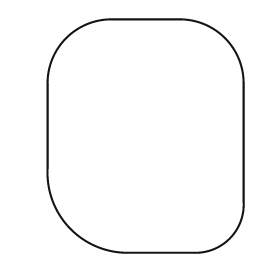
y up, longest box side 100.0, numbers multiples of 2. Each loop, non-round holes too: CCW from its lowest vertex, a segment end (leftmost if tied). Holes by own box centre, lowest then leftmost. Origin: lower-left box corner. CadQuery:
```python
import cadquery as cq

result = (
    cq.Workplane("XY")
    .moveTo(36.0, 0.0)
    .lineTo(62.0, 0.0)
    .threePointArc((78.0, 6.0), (84.0, 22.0))
    .lineTo(84.0, 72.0)
    .threePointArc((76.0, 92.0), (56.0, 100.0))
    .lineTo(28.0, 100.0)
    .threePointArc((8.0, 92.0), (0.0, 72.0))
    .lineTo(0.0, 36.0)
    .threePointArc((10.0, 10.0), (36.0, 0.0))
    .close()
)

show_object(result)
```